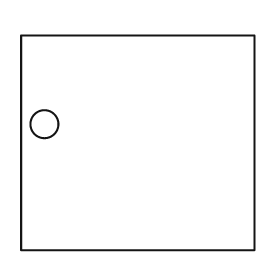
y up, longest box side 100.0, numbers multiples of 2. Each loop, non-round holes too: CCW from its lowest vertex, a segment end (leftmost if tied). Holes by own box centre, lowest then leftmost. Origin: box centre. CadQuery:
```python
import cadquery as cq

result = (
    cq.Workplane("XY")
    .moveTo(-50.0, -46.0)
    .lineTo(50.0, -46.0)
    .lineTo(50.0, 46.0)
    .lineTo(-50.0, 46.0)
    .close()
    .moveTo(-40.0, 8.0)
    .circle(6.0)
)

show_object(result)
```